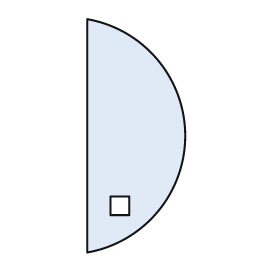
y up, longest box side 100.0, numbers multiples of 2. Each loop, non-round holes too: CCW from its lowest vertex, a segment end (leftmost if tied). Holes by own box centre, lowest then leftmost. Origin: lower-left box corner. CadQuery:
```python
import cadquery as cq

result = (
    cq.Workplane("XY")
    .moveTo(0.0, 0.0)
    .threePointArc((42.0, 50.0), (0.0, 100.0))
    .close()
    .moveTo(10.0, 16.0)
    .lineTo(18.0, 16.0)
    .lineTo(18.0, 24.0)
    .lineTo(10.0, 24.0)
    .close()
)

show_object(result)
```